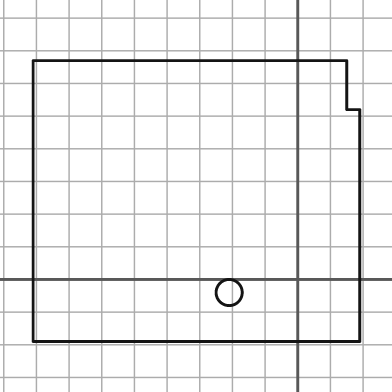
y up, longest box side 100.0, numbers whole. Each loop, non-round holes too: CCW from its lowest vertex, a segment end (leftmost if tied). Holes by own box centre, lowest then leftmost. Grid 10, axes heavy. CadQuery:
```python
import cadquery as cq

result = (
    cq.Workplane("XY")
    .moveTo(-81.0, -19.0)
    .lineTo(19.0, -19.0)
    .lineTo(19.0, 52.0)
    .lineTo(15.0, 52.0)
    .lineTo(15.0, 67.0)
    .lineTo(-81.0, 67.0)
    .close()
    .moveTo(-21.0, -4.0)
    .circle(4.0)
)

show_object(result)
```